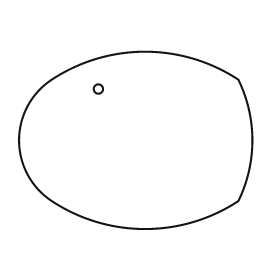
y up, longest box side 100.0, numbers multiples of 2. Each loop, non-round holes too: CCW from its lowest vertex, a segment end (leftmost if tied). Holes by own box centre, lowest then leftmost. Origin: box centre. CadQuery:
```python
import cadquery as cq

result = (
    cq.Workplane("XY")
    .moveTo(-36.0, -26.0)
    .threePointArc((4.0, -38.0), (44.0, -26.0))
    .threePointArc((50.0, 0.0), (44.0, 26.0))
    .threePointArc((4.0, 38.0), (-36.0, 26.0))
    .threePointArc((-50.0, 0.0), (-36.0, -26.0))
    .close()
    .moveTo(-16.0, 22.0)
    .circle(2.0)
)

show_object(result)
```